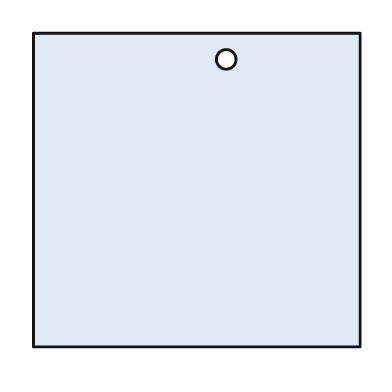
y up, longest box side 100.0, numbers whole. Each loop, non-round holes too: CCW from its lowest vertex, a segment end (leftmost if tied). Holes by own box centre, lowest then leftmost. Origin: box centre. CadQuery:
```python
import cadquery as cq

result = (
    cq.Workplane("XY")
    .moveTo(-50.0, -48.0)
    .lineTo(50.0, -48.0)
    .lineTo(50.0, 48.0)
    .lineTo(-50.0, 48.0)
    .close()
    .moveTo(9.0, 40.0)
    .circle(3.0)
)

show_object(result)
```